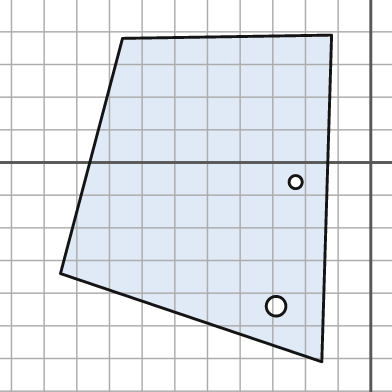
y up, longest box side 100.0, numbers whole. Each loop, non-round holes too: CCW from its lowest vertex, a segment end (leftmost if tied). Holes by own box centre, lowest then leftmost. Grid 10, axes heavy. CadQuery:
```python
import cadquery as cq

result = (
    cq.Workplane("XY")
    .moveTo(-15.0, -61.0)
    .lineTo(-12.0, 39.0)
    .lineTo(-76.0, 38.0)
    .lineTo(-95.0, -34.0)
    .close()
    .moveTo(-29.0, -44.0)
    .circle(3.0)
    .moveTo(-23.0, -6.0)
    .circle(2.0)
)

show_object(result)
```